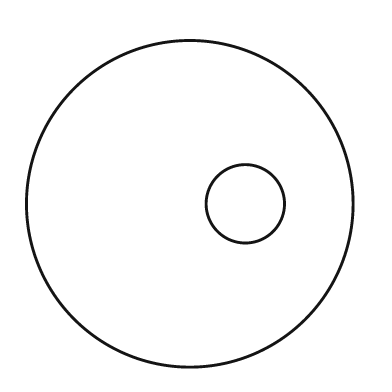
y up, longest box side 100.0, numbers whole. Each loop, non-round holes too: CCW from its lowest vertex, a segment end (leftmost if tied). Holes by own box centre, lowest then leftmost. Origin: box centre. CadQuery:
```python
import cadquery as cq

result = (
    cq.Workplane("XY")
    .moveTo(0.0, 0.0)
    .circle(50.0)
    .moveTo(17.0, 0.0)
    .circle(12.0)
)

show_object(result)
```